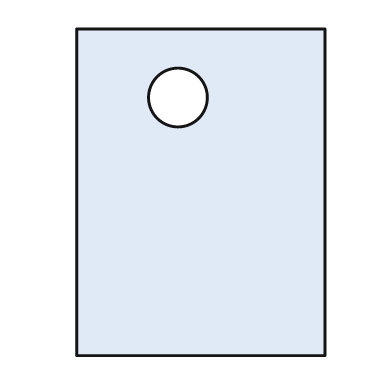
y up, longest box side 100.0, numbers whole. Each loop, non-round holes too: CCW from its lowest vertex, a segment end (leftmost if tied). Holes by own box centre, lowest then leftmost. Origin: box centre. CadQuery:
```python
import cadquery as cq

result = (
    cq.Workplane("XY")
    .moveTo(-38.0, -50.0)
    .lineTo(38.0, -50.0)
    .lineTo(38.0, 50.0)
    .lineTo(-38.0, 50.0)
    .close()
    .moveTo(-7.0, 29.0)
    .circle(9.0)
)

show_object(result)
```